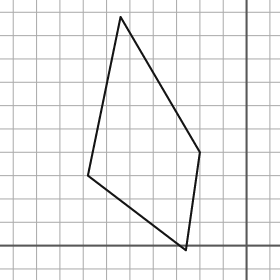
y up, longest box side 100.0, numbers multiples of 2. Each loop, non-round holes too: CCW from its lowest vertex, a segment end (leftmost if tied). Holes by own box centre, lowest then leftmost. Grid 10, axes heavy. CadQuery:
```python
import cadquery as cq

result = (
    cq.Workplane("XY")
    .moveTo(-26.0, -2.0)
    .lineTo(-20.0, 40.0)
    .lineTo(-54.0, 98.0)
    .lineTo(-68.0, 30.0)
    .close()
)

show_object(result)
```